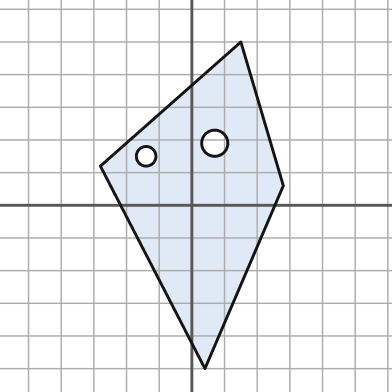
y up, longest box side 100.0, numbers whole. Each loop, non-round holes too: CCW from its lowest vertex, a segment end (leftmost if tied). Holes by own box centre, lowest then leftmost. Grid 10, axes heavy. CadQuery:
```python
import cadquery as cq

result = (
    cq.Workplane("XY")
    .moveTo(4.0, -50.0)
    .lineTo(28.0, 6.0)
    .lineTo(15.0, 50.0)
    .lineTo(-28.0, 12.0)
    .close()
    .moveTo(-14.0, 15.0)
    .circle(3.0)
    .moveTo(7.0, 19.0)
    .circle(4.0)
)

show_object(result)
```